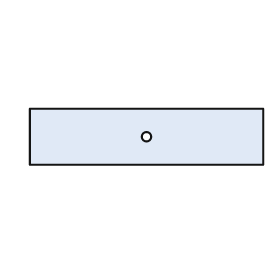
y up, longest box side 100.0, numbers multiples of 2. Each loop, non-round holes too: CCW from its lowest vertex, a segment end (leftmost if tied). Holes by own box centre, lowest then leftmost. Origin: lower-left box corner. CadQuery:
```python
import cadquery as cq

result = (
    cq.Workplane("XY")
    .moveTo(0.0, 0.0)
    .lineTo(100.0, 0.0)
    .lineTo(100.0, 24.0)
    .lineTo(0.0, 24.0)
    .close()
    .moveTo(50.0, 12.0)
    .circle(2.0)
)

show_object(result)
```